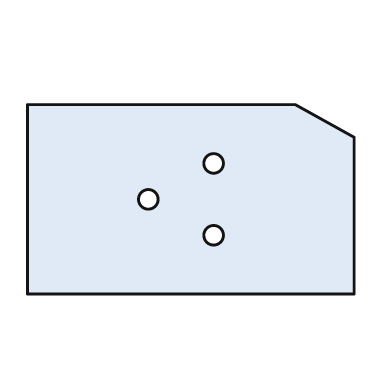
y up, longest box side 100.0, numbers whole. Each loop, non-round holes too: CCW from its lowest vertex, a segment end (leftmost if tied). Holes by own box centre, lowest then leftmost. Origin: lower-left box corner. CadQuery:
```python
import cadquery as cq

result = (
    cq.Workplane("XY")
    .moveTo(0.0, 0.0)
    .lineTo(100.0, 0.0)
    .lineTo(100.0, 48.0)
    .lineTo(82.0, 58.0)
    .lineTo(0.0, 58.0)
    .close()
    .moveTo(57.0, 18.0)
    .circle(3.0)
    .moveTo(37.0, 29.0)
    .circle(3.0)
    .moveTo(57.0, 40.0)
    .circle(3.0)
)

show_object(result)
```